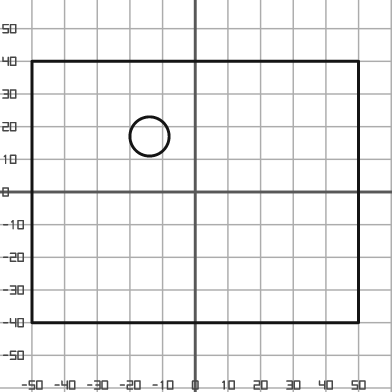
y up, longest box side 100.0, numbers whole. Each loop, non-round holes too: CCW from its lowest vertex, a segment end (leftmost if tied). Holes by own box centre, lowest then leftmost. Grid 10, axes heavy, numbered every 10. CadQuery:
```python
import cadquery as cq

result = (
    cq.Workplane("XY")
    .moveTo(-50.0, -40.0)
    .lineTo(50.0, -40.0)
    .lineTo(50.0, 40.0)
    .lineTo(-50.0, 40.0)
    .close()
    .moveTo(-14.0, 17.0)
    .circle(6.0)
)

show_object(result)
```